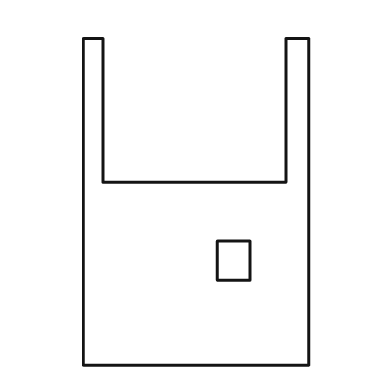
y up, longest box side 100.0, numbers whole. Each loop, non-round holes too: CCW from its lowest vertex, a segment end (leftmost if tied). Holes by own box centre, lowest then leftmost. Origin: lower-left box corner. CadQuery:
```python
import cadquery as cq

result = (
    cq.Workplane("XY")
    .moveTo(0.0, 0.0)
    .lineTo(69.0, 0.0)
    .lineTo(69.0, 100.0)
    .lineTo(62.0, 100.0)
    .lineTo(62.0, 56.0)
    .lineTo(6.0, 56.0)
    .lineTo(6.0, 100.0)
    .lineTo(0.0, 100.0)
    .close()
    .moveTo(41.0, 26.0)
    .lineTo(51.0, 26.0)
    .lineTo(51.0, 38.0)
    .lineTo(41.0, 38.0)
    .close()
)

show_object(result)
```